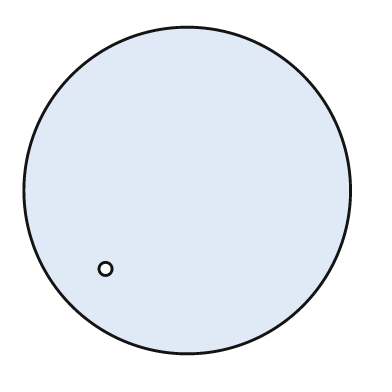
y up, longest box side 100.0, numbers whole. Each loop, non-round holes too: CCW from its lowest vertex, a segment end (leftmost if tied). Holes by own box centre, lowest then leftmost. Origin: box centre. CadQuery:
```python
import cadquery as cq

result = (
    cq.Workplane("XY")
    .moveTo(0.0, 0.0)
    .circle(50.0)
    .moveTo(-25.0, -24.0)
    .circle(2.0)
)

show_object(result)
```